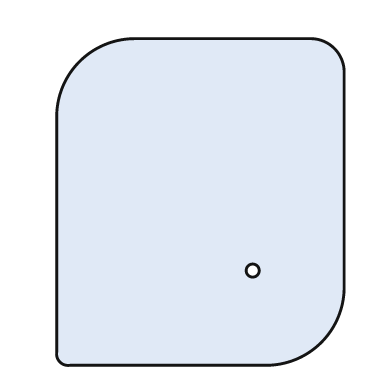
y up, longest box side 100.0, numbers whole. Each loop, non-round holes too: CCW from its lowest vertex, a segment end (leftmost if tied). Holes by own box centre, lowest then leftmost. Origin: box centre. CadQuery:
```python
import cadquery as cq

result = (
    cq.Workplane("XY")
    .moveTo(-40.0, -50.0)
    .lineTo(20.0, -50.0)
    .threePointArc((37.0, -43.0), (44.0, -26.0))
    .lineTo(44.0, 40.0)
    .threePointArc((41.0, 47.0), (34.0, 50.0))
    .lineTo(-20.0, 50.0)
    .threePointArc((-37.0, 43.0), (-44.0, 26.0))
    .lineTo(-44.0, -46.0)
    .threePointArc((-43.0, -49.0), (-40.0, -50.0))
    .close()
    .moveTo(16.0, -21.0)
    .circle(2.0)
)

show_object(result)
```